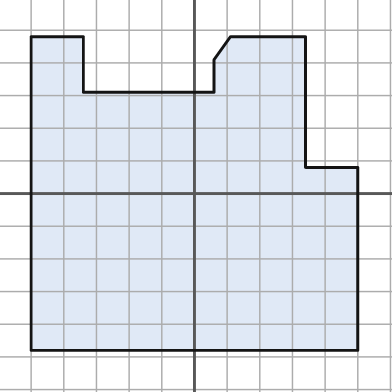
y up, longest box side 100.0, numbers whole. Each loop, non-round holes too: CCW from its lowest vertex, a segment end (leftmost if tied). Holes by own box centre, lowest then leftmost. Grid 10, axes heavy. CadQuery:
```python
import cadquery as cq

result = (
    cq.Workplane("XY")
    .moveTo(-50.0, -48.0)
    .lineTo(50.0, -48.0)
    .lineTo(50.0, 8.0)
    .lineTo(34.0, 8.0)
    .lineTo(34.0, 48.0)
    .lineTo(11.0, 48.0)
    .lineTo(6.0, 41.0)
    .lineTo(6.0, 31.0)
    .lineTo(-34.0, 31.0)
    .lineTo(-34.0, 48.0)
    .lineTo(-50.0, 48.0)
    .close()
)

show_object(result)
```